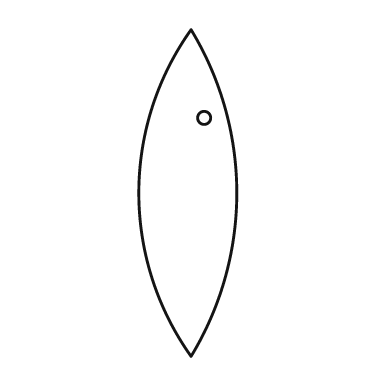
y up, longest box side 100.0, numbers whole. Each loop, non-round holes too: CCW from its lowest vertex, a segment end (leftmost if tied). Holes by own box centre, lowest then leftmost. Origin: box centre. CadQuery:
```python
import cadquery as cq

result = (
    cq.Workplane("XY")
    .moveTo(1.0, -50.0)
    .threePointArc((15.0, 0.0), (1.0, 50.0))
    .threePointArc((-15.0, 0.0), (1.0, -50.0))
    .close()
    .moveTo(5.0, 23.0)
    .circle(2.0)
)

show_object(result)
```